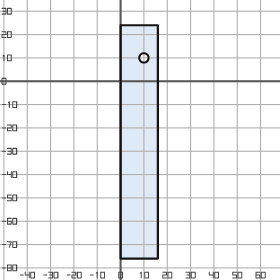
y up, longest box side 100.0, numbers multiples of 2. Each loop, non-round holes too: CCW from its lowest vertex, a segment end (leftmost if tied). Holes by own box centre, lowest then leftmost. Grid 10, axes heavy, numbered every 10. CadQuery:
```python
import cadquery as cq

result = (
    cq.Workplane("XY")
    .moveTo(0.0, -76.0)
    .lineTo(16.0, -76.0)
    .lineTo(16.0, 24.0)
    .lineTo(0.0, 24.0)
    .close()
    .moveTo(10.0, 10.0)
    .circle(2.0)
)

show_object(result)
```